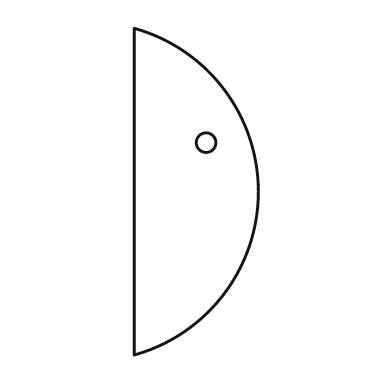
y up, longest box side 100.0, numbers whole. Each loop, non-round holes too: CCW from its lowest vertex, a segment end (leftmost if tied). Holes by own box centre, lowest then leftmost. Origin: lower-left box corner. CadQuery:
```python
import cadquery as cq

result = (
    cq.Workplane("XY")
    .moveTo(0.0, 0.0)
    .threePointArc((38.0, 50.0), (0.0, 100.0))
    .close()
    .moveTo(22.0, 65.0)
    .circle(3.0)
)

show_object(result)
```